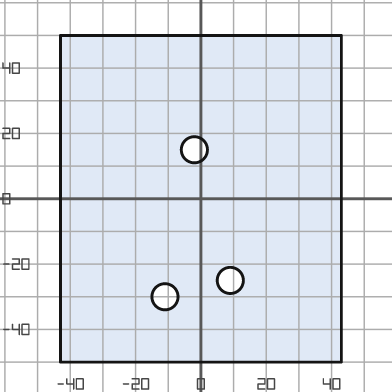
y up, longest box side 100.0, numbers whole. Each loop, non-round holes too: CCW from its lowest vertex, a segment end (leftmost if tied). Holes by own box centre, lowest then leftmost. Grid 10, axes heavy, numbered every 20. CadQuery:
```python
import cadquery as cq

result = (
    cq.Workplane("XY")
    .moveTo(-43.0, -50.0)
    .lineTo(43.0, -50.0)
    .lineTo(43.0, 50.0)
    .lineTo(-43.0, 50.0)
    .close()
    .moveTo(-11.0, -30.0)
    .circle(4.0)
    .moveTo(9.0, -25.0)
    .circle(4.0)
    .moveTo(-2.0, 15.0)
    .circle(4.0)
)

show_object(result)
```